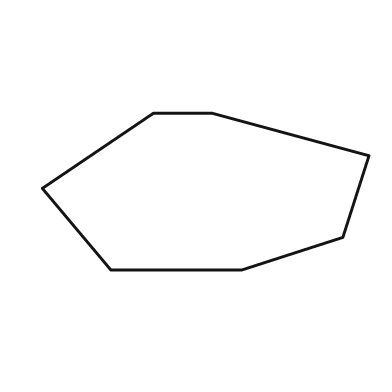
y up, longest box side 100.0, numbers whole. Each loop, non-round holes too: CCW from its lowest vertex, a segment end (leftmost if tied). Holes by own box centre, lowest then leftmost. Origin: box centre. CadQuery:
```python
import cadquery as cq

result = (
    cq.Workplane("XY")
    .moveTo(-29.0, -24.0)
    .lineTo(11.0, -24.0)
    .lineTo(42.0, -14.0)
    .lineTo(50.0, 11.0)
    .lineTo(2.0, 24.0)
    .lineTo(-16.0, 24.0)
    .lineTo(-50.0, 1.0)
    .close()
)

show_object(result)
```